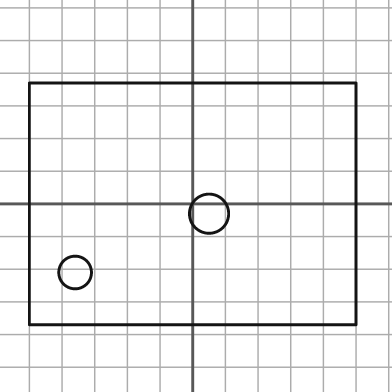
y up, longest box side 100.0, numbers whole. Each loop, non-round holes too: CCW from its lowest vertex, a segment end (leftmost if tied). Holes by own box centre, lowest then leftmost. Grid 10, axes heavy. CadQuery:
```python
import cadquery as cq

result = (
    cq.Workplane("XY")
    .moveTo(-50.0, -37.0)
    .lineTo(50.0, -37.0)
    .lineTo(50.0, 37.0)
    .lineTo(-50.0, 37.0)
    .close()
    .moveTo(-36.0, -21.0)
    .circle(5.0)
    .moveTo(5.0, -3.0)
    .circle(6.0)
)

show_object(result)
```